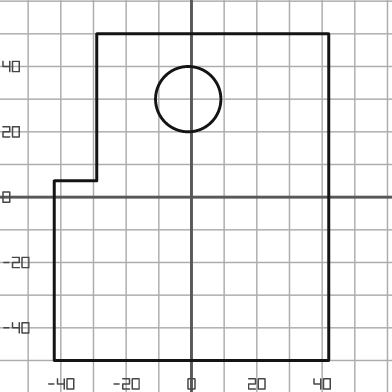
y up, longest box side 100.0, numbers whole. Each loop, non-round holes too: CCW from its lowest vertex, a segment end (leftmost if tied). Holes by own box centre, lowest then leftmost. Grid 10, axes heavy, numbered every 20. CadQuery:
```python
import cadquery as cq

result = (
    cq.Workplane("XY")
    .moveTo(-42.0, -50.0)
    .lineTo(42.0, -50.0)
    .lineTo(42.0, 50.0)
    .lineTo(-29.0, 50.0)
    .lineTo(-29.0, 5.0)
    .lineTo(-42.0, 5.0)
    .close()
    .moveTo(-1.0, 30.0)
    .circle(10.0)
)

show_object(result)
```